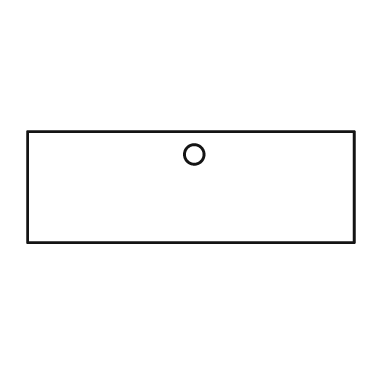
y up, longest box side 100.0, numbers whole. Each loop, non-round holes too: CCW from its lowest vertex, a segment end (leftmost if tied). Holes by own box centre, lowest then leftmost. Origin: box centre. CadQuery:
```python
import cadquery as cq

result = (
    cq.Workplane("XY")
    .moveTo(-50.0, -17.0)
    .lineTo(50.0, -17.0)
    .lineTo(50.0, 17.0)
    .lineTo(-50.0, 17.0)
    .close()
    .moveTo(1.0, 10.0)
    .circle(3.0)
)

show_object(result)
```